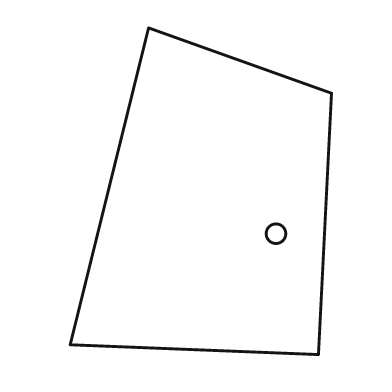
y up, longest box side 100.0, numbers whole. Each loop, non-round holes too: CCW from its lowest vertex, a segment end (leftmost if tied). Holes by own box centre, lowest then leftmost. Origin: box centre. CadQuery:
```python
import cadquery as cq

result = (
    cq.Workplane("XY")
    .moveTo(36.0, -50.0)
    .lineTo(40.0, 30.0)
    .lineTo(-16.0, 50.0)
    .lineTo(-40.0, -47.0)
    .close()
    .moveTo(23.0, -13.0)
    .circle(3.0)
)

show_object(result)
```